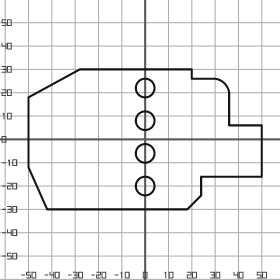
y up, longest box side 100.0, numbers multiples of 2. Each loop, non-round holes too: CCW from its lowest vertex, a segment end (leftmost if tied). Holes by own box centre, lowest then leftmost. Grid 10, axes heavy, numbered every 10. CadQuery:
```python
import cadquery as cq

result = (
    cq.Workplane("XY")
    .moveTo(-42.0, -30.0)
    .lineTo(18.0, -30.0)
    .lineTo(24.0, -24.0)
    .lineTo(24.0, -16.0)
    .lineTo(50.0, -16.0)
    .lineTo(50.0, 6.0)
    .lineTo(36.0, 6.0)
    .lineTo(36.0, 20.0)
    .threePointArc((34.0, 24.0), (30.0, 26.0))
    .lineTo(20.0, 26.0)
    .lineTo(20.0, 30.0)
    .lineTo(-28.0, 30.0)
    .lineTo(-50.0, 18.0)
    .lineTo(-50.0, -12.0)
    .close()
    .moveTo(0.0, -20.0)
    .circle(4.0)
    .moveTo(0.0, -6.0)
    .circle(4.0)
    .moveTo(0.0, 8.0)
    .circle(4.0)
    .moveTo(0.0, 22.0)
    .circle(4.0)
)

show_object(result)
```